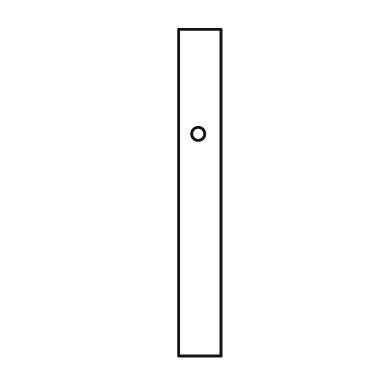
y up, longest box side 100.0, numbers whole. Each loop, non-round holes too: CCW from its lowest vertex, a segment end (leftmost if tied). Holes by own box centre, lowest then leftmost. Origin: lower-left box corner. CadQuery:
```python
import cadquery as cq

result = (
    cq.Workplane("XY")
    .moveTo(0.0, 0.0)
    .lineTo(13.0, 0.0)
    .lineTo(13.0, 100.0)
    .lineTo(0.0, 100.0)
    .close()
    .moveTo(6.0, 68.0)
    .circle(2.0)
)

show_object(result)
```